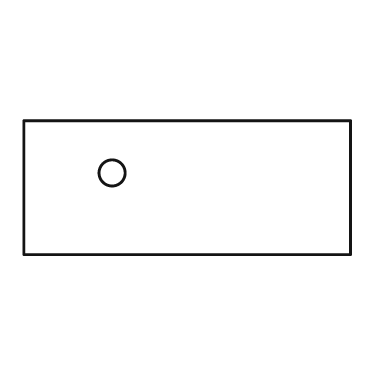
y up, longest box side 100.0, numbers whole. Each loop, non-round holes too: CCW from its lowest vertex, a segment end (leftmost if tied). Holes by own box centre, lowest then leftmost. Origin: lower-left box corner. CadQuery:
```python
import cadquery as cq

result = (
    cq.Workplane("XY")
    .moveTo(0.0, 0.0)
    .lineTo(100.0, 0.0)
    .lineTo(100.0, 41.0)
    .lineTo(0.0, 41.0)
    .close()
    .moveTo(27.0, 25.0)
    .circle(4.0)
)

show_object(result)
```